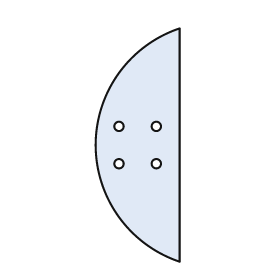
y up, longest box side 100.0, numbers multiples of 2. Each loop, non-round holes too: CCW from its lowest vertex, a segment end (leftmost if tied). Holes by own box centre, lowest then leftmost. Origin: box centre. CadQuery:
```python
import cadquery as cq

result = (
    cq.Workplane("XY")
    .moveTo(18.0, -50.0)
    .lineTo(18.0, 50.0)
    .threePointArc((-18.0, 0.0), (18.0, -50.0))
    .close()
    .moveTo(-8.0, -8.0)
    .circle(2.0)
    .moveTo(8.0, -8.0)
    .circle(2.0)
    .moveTo(-8.0, 8.0)
    .circle(2.0)
    .moveTo(8.0, 8.0)
    .circle(2.0)
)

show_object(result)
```